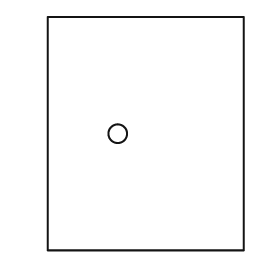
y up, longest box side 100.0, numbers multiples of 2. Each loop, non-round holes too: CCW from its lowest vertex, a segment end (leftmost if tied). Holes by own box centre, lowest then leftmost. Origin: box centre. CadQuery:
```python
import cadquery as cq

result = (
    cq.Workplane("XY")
    .moveTo(-42.0, -50.0)
    .lineTo(42.0, -50.0)
    .lineTo(42.0, 50.0)
    .lineTo(-42.0, 50.0)
    .close()
    .moveTo(-12.0, 0.0)
    .circle(4.0)
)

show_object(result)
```